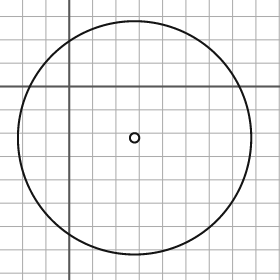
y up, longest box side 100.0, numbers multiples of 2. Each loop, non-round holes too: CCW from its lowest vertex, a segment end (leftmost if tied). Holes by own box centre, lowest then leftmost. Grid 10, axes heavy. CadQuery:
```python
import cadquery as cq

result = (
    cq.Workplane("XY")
    .moveTo(28.0, -22.0)
    .circle(50.0)
    .moveTo(28.0, -22.0)
    .circle(2.0)
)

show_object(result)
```